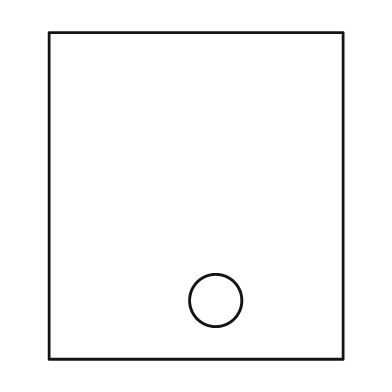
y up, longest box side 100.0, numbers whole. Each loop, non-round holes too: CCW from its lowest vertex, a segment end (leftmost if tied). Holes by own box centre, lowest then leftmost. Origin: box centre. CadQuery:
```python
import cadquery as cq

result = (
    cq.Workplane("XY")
    .moveTo(-45.0, -50.0)
    .lineTo(45.0, -50.0)
    .lineTo(45.0, 50.0)
    .lineTo(-45.0, 50.0)
    .close()
    .moveTo(6.0, -32.0)
    .circle(8.0)
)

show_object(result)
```